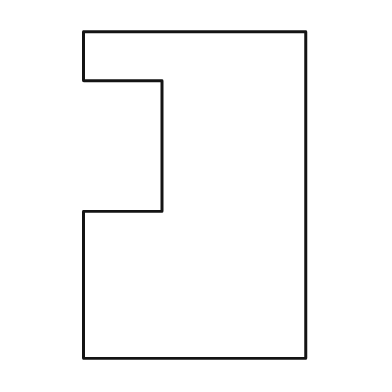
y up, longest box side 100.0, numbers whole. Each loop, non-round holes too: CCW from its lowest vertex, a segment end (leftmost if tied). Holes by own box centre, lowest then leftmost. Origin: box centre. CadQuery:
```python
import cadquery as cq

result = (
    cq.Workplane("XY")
    .moveTo(-34.0, -50.0)
    .lineTo(34.0, -50.0)
    .lineTo(34.0, 50.0)
    .lineTo(-34.0, 50.0)
    .lineTo(-34.0, 35.0)
    .lineTo(-10.0, 35.0)
    .lineTo(-10.0, -5.0)
    .lineTo(-34.0, -5.0)
    .close()
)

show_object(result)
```